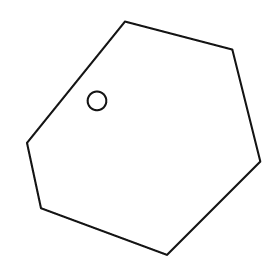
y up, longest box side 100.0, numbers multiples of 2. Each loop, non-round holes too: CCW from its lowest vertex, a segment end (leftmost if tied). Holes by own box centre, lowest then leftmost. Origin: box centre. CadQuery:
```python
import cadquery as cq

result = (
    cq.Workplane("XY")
    .moveTo(10.0, -50.0)
    .lineTo(50.0, -10.0)
    .lineTo(38.0, 38.0)
    .lineTo(-8.0, 50.0)
    .lineTo(-50.0, -2.0)
    .lineTo(-44.0, -30.0)
    .close()
    .moveTo(-20.0, 16.0)
    .circle(4.0)
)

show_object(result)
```